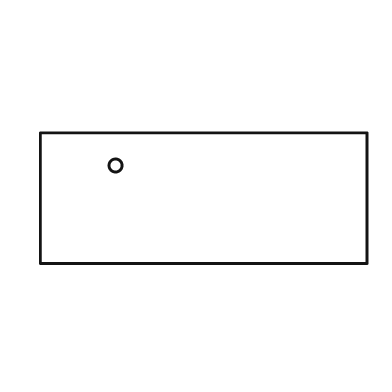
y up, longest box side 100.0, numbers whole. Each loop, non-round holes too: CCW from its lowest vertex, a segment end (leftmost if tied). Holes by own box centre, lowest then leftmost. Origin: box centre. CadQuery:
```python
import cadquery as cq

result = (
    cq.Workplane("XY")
    .moveTo(-50.0, -20.0)
    .lineTo(50.0, -20.0)
    .lineTo(50.0, 20.0)
    .lineTo(-50.0, 20.0)
    .close()
    .moveTo(-27.0, 10.0)
    .circle(2.0)
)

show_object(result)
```